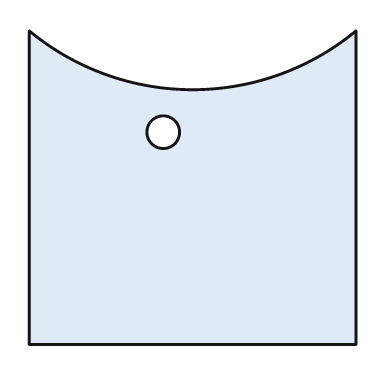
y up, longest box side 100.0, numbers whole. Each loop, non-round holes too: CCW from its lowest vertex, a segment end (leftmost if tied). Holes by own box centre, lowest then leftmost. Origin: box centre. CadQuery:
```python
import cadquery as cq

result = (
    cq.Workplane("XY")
    .moveTo(-50.0, -48.0)
    .lineTo(50.0, -48.0)
    .lineTo(50.0, 48.0)
    .threePointArc((0.0, 30.0), (-50.0, 48.0))
    .close()
    .moveTo(-9.0, 17.0)
    .circle(5.0)
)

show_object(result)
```